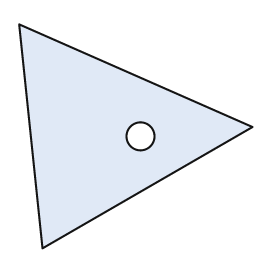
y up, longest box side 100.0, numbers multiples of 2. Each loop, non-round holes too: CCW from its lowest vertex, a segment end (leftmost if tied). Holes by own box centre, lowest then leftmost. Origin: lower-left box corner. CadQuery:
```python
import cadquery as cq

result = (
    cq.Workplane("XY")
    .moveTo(10.0, 0.0)
    .lineTo(100.0, 52.0)
    .lineTo(0.0, 96.0)
    .close()
    .moveTo(52.0, 48.0)
    .circle(6.0)
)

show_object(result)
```